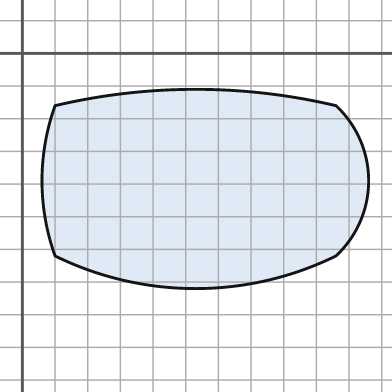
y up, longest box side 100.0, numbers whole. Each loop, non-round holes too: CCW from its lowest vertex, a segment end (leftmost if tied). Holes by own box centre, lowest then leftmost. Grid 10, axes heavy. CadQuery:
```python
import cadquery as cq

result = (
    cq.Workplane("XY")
    .moveTo(10.0, -62.0)
    .threePointArc((53.0, -72.0), (96.0, -62.0))
    .threePointArc((106.0, -39.0), (96.0, -16.0))
    .threePointArc((53.0, -11.0), (10.0, -16.0))
    .threePointArc((6.0, -39.0), (10.0, -62.0))
    .close()
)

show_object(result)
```